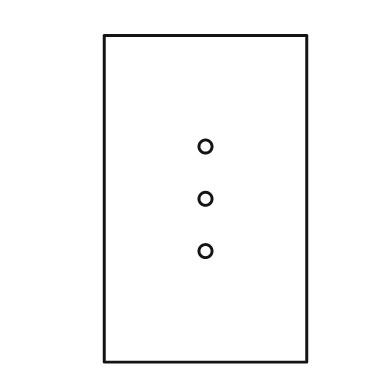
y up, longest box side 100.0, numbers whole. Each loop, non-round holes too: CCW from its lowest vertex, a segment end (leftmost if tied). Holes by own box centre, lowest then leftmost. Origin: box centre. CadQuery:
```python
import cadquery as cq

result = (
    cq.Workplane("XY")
    .moveTo(-31.0, -50.0)
    .lineTo(31.0, -50.0)
    .lineTo(31.0, 50.0)
    .lineTo(-31.0, 50.0)
    .close()
    .moveTo(0.0, -16.0)
    .circle(2.0)
    .moveTo(0.0, 0.0)
    .circle(2.0)
    .moveTo(0.0, 16.0)
    .circle(2.0)
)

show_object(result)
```